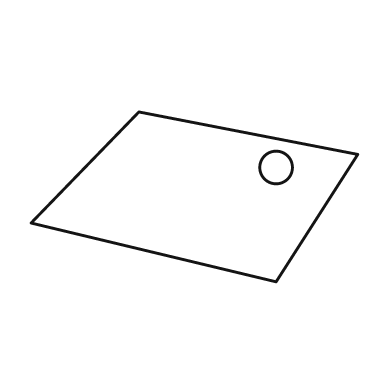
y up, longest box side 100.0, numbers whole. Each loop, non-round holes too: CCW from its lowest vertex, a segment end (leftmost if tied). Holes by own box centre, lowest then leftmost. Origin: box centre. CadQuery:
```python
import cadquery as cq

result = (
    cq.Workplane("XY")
    .moveTo(25.0, -26.0)
    .lineTo(50.0, 13.0)
    .lineTo(-17.0, 26.0)
    .lineTo(-50.0, -8.0)
    .close()
    .moveTo(25.0, 9.0)
    .circle(5.0)
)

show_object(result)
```